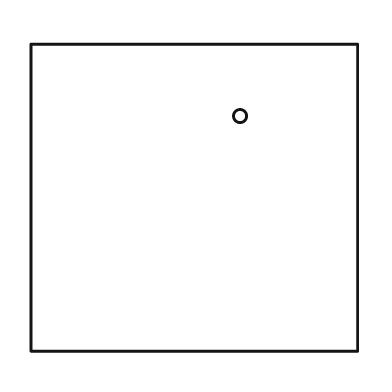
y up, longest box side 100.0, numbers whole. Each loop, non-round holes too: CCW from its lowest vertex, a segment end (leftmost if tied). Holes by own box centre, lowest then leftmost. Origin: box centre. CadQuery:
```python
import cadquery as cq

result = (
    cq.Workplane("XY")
    .moveTo(-50.0, -47.0)
    .lineTo(50.0, -47.0)
    .lineTo(50.0, 47.0)
    .lineTo(-50.0, 47.0)
    .close()
    .moveTo(14.0, 25.0)
    .circle(2.0)
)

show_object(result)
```